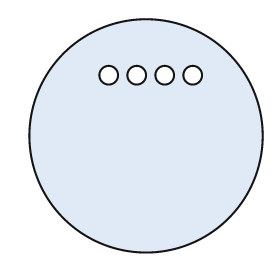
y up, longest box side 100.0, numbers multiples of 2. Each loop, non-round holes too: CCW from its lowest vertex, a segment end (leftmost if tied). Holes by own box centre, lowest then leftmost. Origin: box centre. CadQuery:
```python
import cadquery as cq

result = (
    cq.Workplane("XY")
    .moveTo(0.0, 0.0)
    .circle(50.0)
    .moveTo(-16.0, 26.0)
    .circle(4.0)
    .moveTo(-4.0, 26.0)
    .circle(4.0)
    .moveTo(8.0, 26.0)
    .circle(4.0)
    .moveTo(20.0, 26.0)
    .circle(4.0)
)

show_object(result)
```